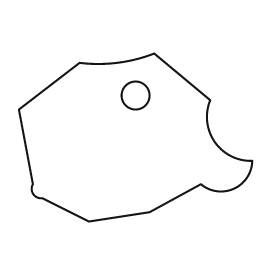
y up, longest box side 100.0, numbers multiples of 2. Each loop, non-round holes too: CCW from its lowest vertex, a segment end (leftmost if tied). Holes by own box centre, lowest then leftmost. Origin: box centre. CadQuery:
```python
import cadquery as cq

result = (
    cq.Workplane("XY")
    .moveTo(-20.0, -36.0)
    .lineTo(6.0, -32.0)
    .lineTo(28.0, -20.0)
    .threePointArc((42.0, -22.0), (50.0, -10.0))
    .threePointArc((34.0, -2.0), (32.0, 16.0))
    .lineTo(8.0, 36.0)
    .threePointArc((-8.0, 32.0), (-24.0, 32.0))
    .lineTo(-50.0, 12.0)
    .lineTo(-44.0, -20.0)
    .threePointArc((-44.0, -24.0), (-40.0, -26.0))
    .close()
    .moveTo(0.0, 18.0)
    .circle(6.0)
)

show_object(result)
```